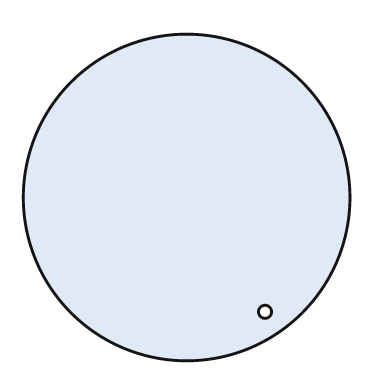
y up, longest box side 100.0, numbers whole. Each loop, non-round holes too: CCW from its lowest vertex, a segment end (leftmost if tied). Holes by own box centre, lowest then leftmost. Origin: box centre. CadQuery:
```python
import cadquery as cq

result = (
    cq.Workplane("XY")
    .moveTo(0.0, 0.0)
    .circle(50.0)
    .moveTo(24.0, -35.0)
    .circle(2.0)
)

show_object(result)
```